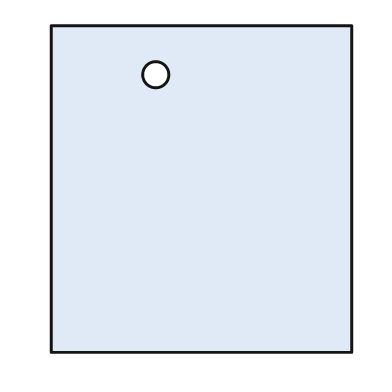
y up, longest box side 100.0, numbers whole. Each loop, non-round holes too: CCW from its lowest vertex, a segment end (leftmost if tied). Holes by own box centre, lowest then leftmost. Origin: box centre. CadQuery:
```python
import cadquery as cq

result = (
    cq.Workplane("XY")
    .moveTo(-46.0, -50.0)
    .lineTo(46.0, -50.0)
    .lineTo(46.0, 50.0)
    .lineTo(-46.0, 50.0)
    .close()
    .moveTo(-14.0, 35.0)
    .circle(4.0)
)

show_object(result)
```